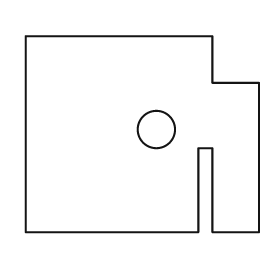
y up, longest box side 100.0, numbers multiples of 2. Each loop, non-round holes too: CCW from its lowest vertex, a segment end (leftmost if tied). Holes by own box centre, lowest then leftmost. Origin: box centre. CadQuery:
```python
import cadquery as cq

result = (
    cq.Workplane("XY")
    .moveTo(-50.0, -42.0)
    .lineTo(24.0, -42.0)
    .lineTo(24.0, -6.0)
    .lineTo(30.0, -6.0)
    .lineTo(30.0, -42.0)
    .lineTo(50.0, -42.0)
    .lineTo(50.0, 22.0)
    .lineTo(30.0, 22.0)
    .lineTo(30.0, 42.0)
    .lineTo(-50.0, 42.0)
    .close()
    .moveTo(6.0, 2.0)
    .circle(8.0)
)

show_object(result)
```